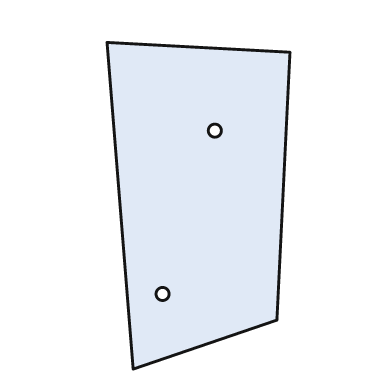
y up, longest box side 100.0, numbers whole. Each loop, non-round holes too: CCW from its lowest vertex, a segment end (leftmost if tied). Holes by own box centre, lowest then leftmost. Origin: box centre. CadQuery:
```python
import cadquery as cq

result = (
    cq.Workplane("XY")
    .moveTo(-20.0, -50.0)
    .lineTo(24.0, -35.0)
    .lineTo(28.0, 47.0)
    .lineTo(-28.0, 50.0)
    .close()
    .moveTo(-11.0, -27.0)
    .circle(2.0)
    .moveTo(5.0, 23.0)
    .circle(2.0)
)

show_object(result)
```